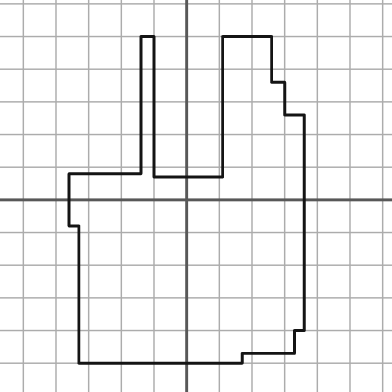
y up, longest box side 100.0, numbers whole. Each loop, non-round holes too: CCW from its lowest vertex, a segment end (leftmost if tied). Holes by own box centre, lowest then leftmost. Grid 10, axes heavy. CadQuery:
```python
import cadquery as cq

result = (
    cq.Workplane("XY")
    .moveTo(-33.0, -50.0)
    .lineTo(17.0, -50.0)
    .lineTo(17.0, -47.0)
    .lineTo(33.0, -47.0)
    .lineTo(33.0, -40.0)
    .lineTo(36.0, -40.0)
    .lineTo(36.0, 26.0)
    .lineTo(30.0, 26.0)
    .lineTo(30.0, 36.0)
    .lineTo(26.0, 36.0)
    .lineTo(26.0, 50.0)
    .lineTo(11.0, 50.0)
    .lineTo(11.0, 7.0)
    .lineTo(-10.0, 7.0)
    .lineTo(-10.0, 50.0)
    .lineTo(-14.0, 50.0)
    .lineTo(-14.0, 8.0)
    .lineTo(-36.0, 8.0)
    .lineTo(-36.0, -8.0)
    .lineTo(-33.0, -8.0)
    .close()
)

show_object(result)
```